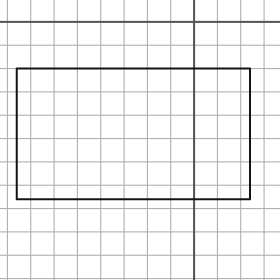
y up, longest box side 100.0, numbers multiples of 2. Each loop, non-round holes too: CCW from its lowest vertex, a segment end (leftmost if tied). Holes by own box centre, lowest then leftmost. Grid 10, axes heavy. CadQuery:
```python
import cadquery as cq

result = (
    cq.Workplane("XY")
    .moveTo(-76.0, -76.0)
    .lineTo(24.0, -76.0)
    .lineTo(24.0, -20.0)
    .lineTo(-76.0, -20.0)
    .close()
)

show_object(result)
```